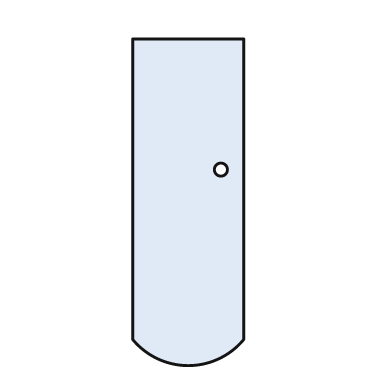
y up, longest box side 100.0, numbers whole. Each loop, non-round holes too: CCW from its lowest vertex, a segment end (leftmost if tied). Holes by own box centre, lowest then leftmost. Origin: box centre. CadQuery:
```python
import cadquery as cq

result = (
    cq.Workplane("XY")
    .moveTo(-17.0, -42.0)
    .threePointArc((0.0, -50.0), (17.0, -42.0))
    .lineTo(17.0, 50.0)
    .lineTo(-17.0, 50.0)
    .close()
    .moveTo(10.0, 10.0)
    .circle(2.0)
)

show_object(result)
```